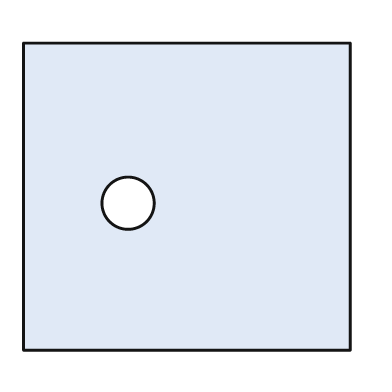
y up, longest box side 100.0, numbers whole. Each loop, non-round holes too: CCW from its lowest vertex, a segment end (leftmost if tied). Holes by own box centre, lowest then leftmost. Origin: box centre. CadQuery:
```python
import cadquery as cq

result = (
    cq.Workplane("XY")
    .moveTo(-50.0, -47.0)
    .lineTo(50.0, -47.0)
    .lineTo(50.0, 47.0)
    .lineTo(-50.0, 47.0)
    .close()
    .moveTo(-18.0, -2.0)
    .circle(8.0)
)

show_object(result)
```